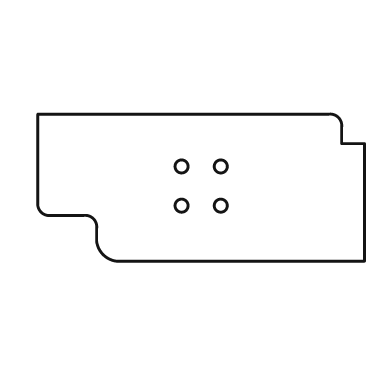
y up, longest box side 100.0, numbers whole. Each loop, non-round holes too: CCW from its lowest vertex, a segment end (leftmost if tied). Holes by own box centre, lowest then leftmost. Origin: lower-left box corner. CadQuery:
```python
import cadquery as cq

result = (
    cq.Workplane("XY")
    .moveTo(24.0, 0.0)
    .lineTo(100.0, 0.0)
    .lineTo(100.0, 36.0)
    .lineTo(93.0, 36.0)
    .lineTo(93.0, 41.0)
    .threePointArc((92.0, 44.0), (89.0, 45.0))
    .lineTo(0.0, 45.0)
    .lineTo(0.0, 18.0)
    .threePointArc((1.0, 15.0), (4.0, 14.0))
    .lineTo(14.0, 14.0)
    .threePointArc((17.0, 13.0), (18.0, 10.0))
    .lineTo(18.0, 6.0)
    .threePointArc((20.0, 2.0), (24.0, 0.0))
    .close()
    .moveTo(44.0, 17.0)
    .circle(2.0)
    .moveTo(56.0, 17.0)
    .circle(2.0)
    .moveTo(44.0, 29.0)
    .circle(2.0)
    .moveTo(56.0, 29.0)
    .circle(2.0)
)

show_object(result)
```